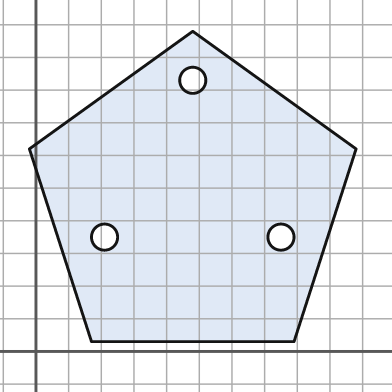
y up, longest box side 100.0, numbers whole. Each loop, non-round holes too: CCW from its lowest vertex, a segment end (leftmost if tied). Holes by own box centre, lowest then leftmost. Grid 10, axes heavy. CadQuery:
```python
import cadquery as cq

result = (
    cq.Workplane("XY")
    .moveTo(17.0, 3.0)
    .lineTo(79.0, 3.0)
    .lineTo(98.0, 62.0)
    .lineTo(48.0, 98.0)
    .lineTo(-2.0, 62.0)
    .close()
    .moveTo(21.0, 35.0)
    .circle(4.0)
    .moveTo(75.0, 35.0)
    .circle(4.0)
    .moveTo(48.0, 83.0)
    .circle(4.0)
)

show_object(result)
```